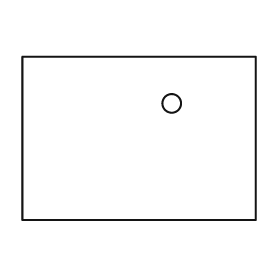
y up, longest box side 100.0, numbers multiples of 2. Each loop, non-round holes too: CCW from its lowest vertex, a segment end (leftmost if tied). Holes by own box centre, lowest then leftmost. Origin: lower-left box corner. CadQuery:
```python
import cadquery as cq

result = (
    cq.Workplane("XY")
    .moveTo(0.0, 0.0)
    .lineTo(100.0, 0.0)
    .lineTo(100.0, 70.0)
    .lineTo(0.0, 70.0)
    .close()
    .moveTo(64.0, 50.0)
    .circle(4.0)
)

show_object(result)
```